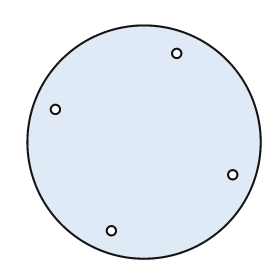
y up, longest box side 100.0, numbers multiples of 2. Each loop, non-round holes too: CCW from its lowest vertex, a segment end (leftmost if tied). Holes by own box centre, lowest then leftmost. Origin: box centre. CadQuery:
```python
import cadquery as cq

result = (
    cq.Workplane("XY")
    .moveTo(0.0, 0.0)
    .circle(50.0)
    .moveTo(-14.0, -38.0)
    .circle(2.0)
    .moveTo(38.0, -14.0)
    .circle(2.0)
    .moveTo(-38.0, 14.0)
    .circle(2.0)
    .moveTo(14.0, 38.0)
    .circle(2.0)
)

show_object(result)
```